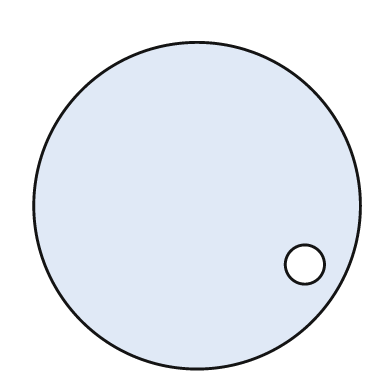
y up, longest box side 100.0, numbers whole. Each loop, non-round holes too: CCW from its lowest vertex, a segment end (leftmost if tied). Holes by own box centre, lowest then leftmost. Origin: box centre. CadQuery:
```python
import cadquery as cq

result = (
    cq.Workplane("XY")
    .moveTo(0.0, 0.0)
    .circle(50.0)
    .moveTo(33.0, -18.0)
    .circle(6.0)
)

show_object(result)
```